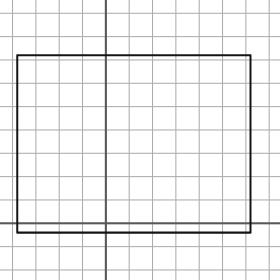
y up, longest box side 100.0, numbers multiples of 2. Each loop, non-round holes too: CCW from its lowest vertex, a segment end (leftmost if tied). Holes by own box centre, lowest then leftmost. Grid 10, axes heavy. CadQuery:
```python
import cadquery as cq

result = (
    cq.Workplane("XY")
    .moveTo(-38.0, -4.0)
    .lineTo(62.0, -4.0)
    .lineTo(62.0, 72.0)
    .lineTo(-38.0, 72.0)
    .close()
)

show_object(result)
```